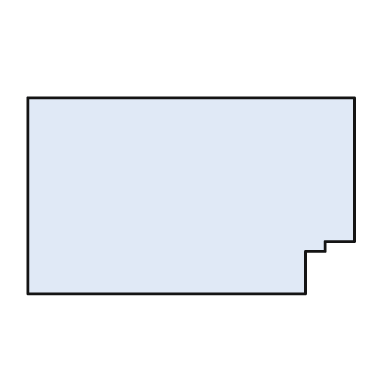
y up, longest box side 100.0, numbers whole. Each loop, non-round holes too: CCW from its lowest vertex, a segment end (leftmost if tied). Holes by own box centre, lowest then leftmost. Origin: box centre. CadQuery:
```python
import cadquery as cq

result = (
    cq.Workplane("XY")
    .moveTo(-50.0, -30.0)
    .lineTo(35.0, -30.0)
    .lineTo(35.0, -17.0)
    .lineTo(41.0, -17.0)
    .lineTo(41.0, -14.0)
    .lineTo(50.0, -14.0)
    .lineTo(50.0, 30.0)
    .lineTo(-50.0, 30.0)
    .close()
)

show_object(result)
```